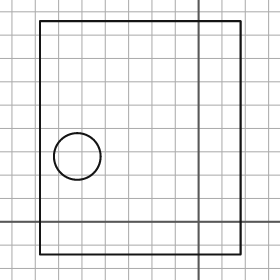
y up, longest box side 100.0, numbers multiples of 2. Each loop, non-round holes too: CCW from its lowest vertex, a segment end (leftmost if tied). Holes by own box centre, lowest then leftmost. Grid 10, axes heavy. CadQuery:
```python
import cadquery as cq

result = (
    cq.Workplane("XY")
    .moveTo(-68.0, -14.0)
    .lineTo(18.0, -14.0)
    .lineTo(18.0, 86.0)
    .lineTo(-68.0, 86.0)
    .close()
    .moveTo(-52.0, 28.0)
    .circle(10.0)
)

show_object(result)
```